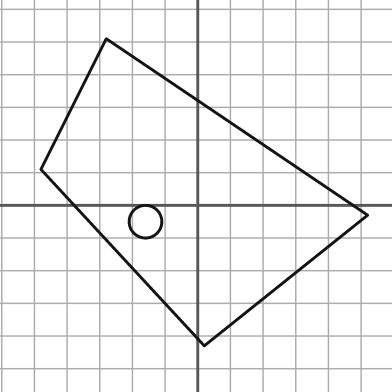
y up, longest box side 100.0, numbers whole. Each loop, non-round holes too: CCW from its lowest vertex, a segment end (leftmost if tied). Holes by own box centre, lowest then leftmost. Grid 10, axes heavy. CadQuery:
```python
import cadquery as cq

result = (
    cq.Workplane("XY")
    .moveTo(2.0, -43.0)
    .lineTo(52.0, -3.0)
    .lineTo(-28.0, 51.0)
    .lineTo(-48.0, 11.0)
    .close()
    .moveTo(-16.0, -5.0)
    .circle(5.0)
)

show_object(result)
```